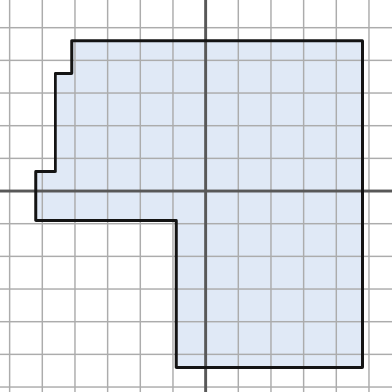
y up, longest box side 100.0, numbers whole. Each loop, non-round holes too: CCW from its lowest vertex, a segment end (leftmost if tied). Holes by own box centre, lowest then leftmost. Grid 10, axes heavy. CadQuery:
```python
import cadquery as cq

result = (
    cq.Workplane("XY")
    .moveTo(-9.0, -54.0)
    .lineTo(48.0, -54.0)
    .lineTo(48.0, 46.0)
    .lineTo(-41.0, 46.0)
    .lineTo(-41.0, 36.0)
    .lineTo(-46.0, 36.0)
    .lineTo(-46.0, 6.0)
    .lineTo(-52.0, 6.0)
    .lineTo(-52.0, -9.0)
    .lineTo(-9.0, -9.0)
    .close()
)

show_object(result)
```